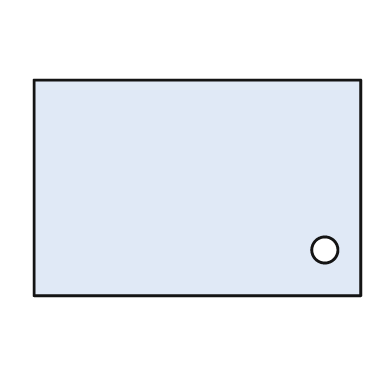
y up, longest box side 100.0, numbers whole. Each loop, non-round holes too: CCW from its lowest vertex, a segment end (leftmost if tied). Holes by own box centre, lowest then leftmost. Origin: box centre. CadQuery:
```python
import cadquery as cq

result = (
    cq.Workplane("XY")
    .moveTo(-50.0, -33.0)
    .lineTo(50.0, -33.0)
    .lineTo(50.0, 33.0)
    .lineTo(-50.0, 33.0)
    .close()
    .moveTo(39.0, -19.0)
    .circle(4.0)
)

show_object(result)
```